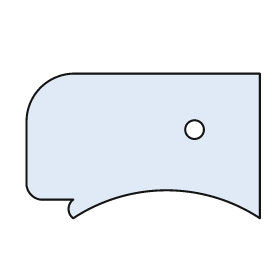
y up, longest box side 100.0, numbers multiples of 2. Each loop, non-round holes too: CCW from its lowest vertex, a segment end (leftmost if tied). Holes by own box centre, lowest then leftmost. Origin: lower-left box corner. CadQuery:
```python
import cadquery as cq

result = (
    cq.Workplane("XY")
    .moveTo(20.0, 0.0)
    .threePointArc((60.0, 12.0), (100.0, 0.0))
    .lineTo(100.0, 62.0)
    .lineTo(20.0, 62.0)
    .threePointArc((6.0, 56.0), (0.0, 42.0))
    .lineTo(0.0, 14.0)
    .threePointArc((2.0, 10.0), (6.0, 8.0))
    .lineTo(20.0, 8.0)
    .threePointArc((18.0, 4.0), (20.0, 0.0))
    .close()
    .moveTo(72.0, 38.0)
    .circle(4.0)
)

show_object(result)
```